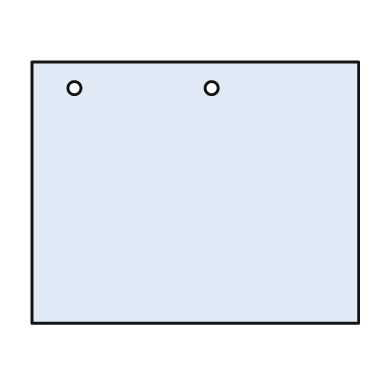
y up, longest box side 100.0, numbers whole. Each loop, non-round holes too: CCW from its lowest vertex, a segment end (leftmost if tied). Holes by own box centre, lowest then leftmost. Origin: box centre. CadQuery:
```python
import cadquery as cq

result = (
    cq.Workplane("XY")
    .moveTo(-50.0, -40.0)
    .lineTo(50.0, -40.0)
    .lineTo(50.0, 40.0)
    .lineTo(-50.0, 40.0)
    .close()
    .moveTo(-37.0, 32.0)
    .circle(2.0)
    .moveTo(5.0, 32.0)
    .circle(2.0)
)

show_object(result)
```